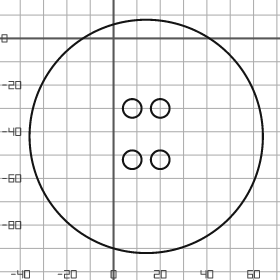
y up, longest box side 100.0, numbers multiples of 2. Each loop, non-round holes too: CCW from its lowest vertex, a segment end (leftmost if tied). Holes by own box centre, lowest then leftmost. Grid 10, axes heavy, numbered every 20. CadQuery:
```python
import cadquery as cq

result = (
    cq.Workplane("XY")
    .moveTo(14.0, -42.0)
    .circle(50.0)
    .moveTo(8.0, -52.0)
    .circle(4.0)
    .moveTo(20.0, -52.0)
    .circle(4.0)
    .moveTo(8.0, -30.0)
    .circle(4.0)
    .moveTo(20.0, -30.0)
    .circle(4.0)
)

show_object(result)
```